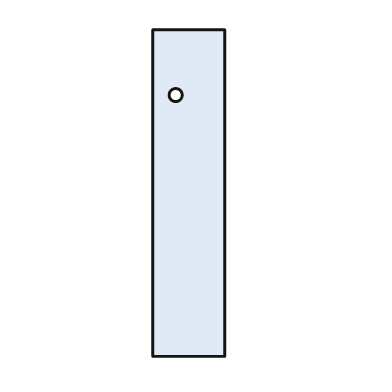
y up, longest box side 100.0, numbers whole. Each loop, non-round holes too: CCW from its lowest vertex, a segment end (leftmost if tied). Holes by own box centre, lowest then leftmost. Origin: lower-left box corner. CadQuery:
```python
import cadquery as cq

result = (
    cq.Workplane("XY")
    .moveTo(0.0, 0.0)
    .lineTo(22.0, 0.0)
    .lineTo(22.0, 100.0)
    .lineTo(0.0, 100.0)
    .close()
    .moveTo(7.0, 80.0)
    .circle(2.0)
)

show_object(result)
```